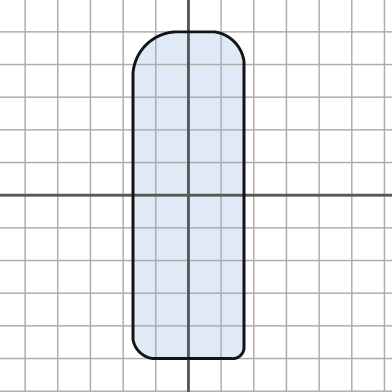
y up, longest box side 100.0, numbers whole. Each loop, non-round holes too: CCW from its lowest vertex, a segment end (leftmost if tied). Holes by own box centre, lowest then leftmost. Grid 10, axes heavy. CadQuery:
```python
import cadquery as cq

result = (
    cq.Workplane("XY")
    .moveTo(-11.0, -50.0)
    .lineTo(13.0, -50.0)
    .threePointArc((16.0, -49.0), (17.0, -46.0))
    .lineTo(17.0, 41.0)
    .threePointArc((14.0, 47.0), (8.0, 50.0))
    .lineTo(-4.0, 50.0)
    .threePointArc((-13.0, 46.0), (-17.0, 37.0))
    .lineTo(-17.0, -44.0)
    .threePointArc((-15.0, -48.0), (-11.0, -50.0))
    .close()
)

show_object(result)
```